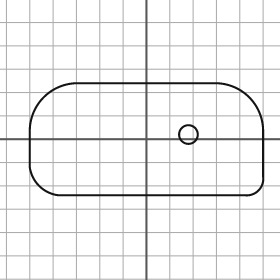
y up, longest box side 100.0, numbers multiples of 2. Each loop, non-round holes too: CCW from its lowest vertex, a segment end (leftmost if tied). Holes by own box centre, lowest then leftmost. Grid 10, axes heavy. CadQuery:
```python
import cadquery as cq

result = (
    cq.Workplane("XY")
    .moveTo(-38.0, -24.0)
    .lineTo(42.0, -24.0)
    .threePointArc((48.0, -22.0), (50.0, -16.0))
    .lineTo(50.0, 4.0)
    .threePointArc((44.0, 18.0), (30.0, 24.0))
    .lineTo(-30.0, 24.0)
    .threePointArc((-44.0, 18.0), (-50.0, 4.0))
    .lineTo(-50.0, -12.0)
    .threePointArc((-46.0, -20.0), (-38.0, -24.0))
    .close()
    .moveTo(18.0, 2.0)
    .circle(4.0)
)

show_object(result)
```